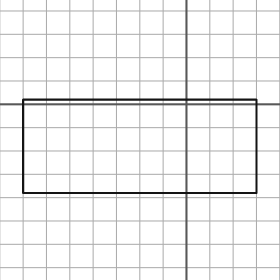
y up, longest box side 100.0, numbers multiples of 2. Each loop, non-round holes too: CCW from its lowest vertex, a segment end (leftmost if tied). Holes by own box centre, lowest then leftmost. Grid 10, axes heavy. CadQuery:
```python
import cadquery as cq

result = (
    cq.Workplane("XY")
    .moveTo(-70.0, -38.0)
    .lineTo(30.0, -38.0)
    .lineTo(30.0, 2.0)
    .lineTo(-70.0, 2.0)
    .close()
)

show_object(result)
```